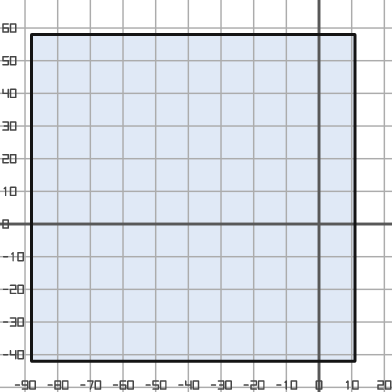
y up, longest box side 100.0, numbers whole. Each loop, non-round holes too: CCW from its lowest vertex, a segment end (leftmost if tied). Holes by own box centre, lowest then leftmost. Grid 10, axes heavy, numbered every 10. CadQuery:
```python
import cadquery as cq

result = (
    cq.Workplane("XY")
    .moveTo(-88.0, -42.0)
    .lineTo(11.0, -42.0)
    .lineTo(11.0, 58.0)
    .lineTo(-88.0, 58.0)
    .close()
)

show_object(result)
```